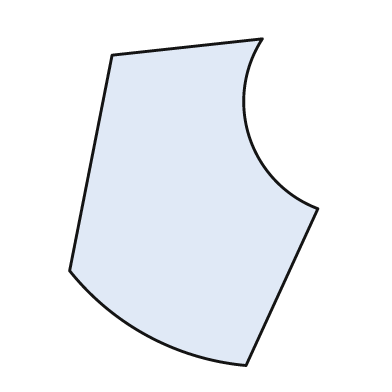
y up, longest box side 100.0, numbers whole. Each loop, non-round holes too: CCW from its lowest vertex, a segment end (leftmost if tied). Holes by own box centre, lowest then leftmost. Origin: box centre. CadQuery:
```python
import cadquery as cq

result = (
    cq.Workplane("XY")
    .moveTo(16.0, -50.0)
    .lineTo(38.0, -2.0)
    .threePointArc((17.0, 20.0), (21.0, 50.0))
    .lineTo(-25.0, 45.0)
    .lineTo(-38.0, -21.0)
    .threePointArc((-14.0, -41.0), (16.0, -50.0))
    .close()
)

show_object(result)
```